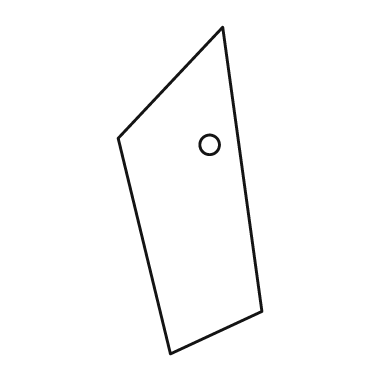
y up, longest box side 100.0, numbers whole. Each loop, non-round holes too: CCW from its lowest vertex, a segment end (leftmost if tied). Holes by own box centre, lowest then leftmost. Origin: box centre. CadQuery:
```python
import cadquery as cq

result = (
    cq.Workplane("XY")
    .moveTo(-6.0, -50.0)
    .lineTo(22.0, -37.0)
    .lineTo(10.0, 50.0)
    .lineTo(-22.0, 16.0)
    .close()
    .moveTo(6.0, 14.0)
    .circle(3.0)
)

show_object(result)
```